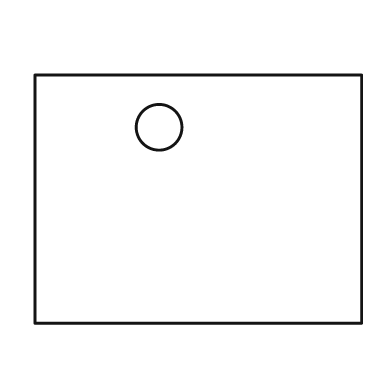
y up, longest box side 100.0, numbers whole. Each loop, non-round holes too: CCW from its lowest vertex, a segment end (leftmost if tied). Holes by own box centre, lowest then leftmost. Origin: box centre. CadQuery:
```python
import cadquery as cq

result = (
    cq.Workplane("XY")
    .moveTo(-50.0, -38.0)
    .lineTo(50.0, -38.0)
    .lineTo(50.0, 38.0)
    .lineTo(-50.0, 38.0)
    .close()
    .moveTo(-12.0, 22.0)
    .circle(7.0)
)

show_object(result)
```